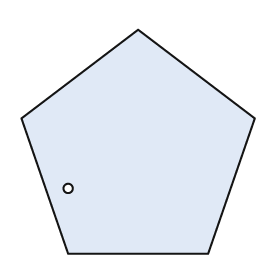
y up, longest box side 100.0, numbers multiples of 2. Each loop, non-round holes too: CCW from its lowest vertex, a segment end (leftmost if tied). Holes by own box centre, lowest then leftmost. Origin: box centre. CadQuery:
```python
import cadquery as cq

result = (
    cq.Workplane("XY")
    .moveTo(-30.0, -48.0)
    .lineTo(30.0, -48.0)
    .lineTo(50.0, 10.0)
    .lineTo(0.0, 48.0)
    .lineTo(-50.0, 10.0)
    .close()
    .moveTo(-30.0, -20.0)
    .circle(2.0)
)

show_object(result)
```